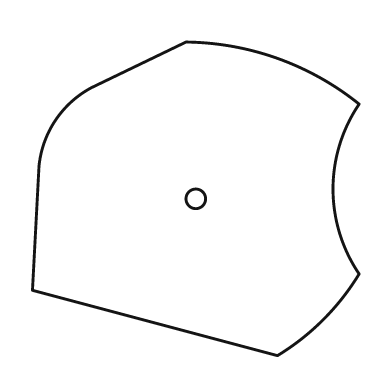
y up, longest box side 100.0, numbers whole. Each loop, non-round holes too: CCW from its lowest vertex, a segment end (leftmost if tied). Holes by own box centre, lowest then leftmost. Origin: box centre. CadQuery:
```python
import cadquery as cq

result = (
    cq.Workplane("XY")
    .moveTo(25.0, -48.0)
    .threePointArc((39.0, -37.0), (50.0, -23.0))
    .threePointArc((42.0, 3.0), (50.0, 29.0))
    .threePointArc((25.0, 43.0), (-3.0, 48.0))
    .lineTo(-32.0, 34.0)
    .threePointArc((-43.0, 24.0), (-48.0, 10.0))
    .lineTo(-50.0, -28.0)
    .close()
    .moveTo(0.0, 0.0)
    .circle(3.0)
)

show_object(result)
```